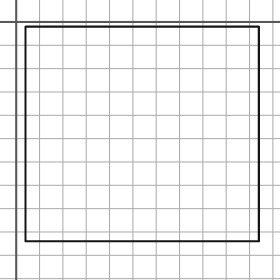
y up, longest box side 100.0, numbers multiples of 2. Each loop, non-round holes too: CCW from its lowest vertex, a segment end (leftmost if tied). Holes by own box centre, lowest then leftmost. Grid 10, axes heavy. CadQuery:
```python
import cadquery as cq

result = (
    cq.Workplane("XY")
    .moveTo(4.0, -94.0)
    .lineTo(104.0, -94.0)
    .lineTo(104.0, -2.0)
    .lineTo(4.0, -2.0)
    .close()
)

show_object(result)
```